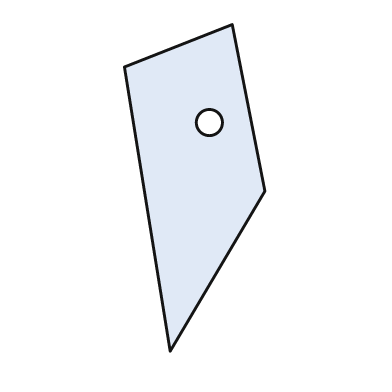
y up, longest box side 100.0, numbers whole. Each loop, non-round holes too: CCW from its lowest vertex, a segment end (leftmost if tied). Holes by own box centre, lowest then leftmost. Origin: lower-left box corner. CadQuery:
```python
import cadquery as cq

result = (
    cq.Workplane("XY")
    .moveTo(14.0, 0.0)
    .lineTo(43.0, 49.0)
    .lineTo(33.0, 100.0)
    .lineTo(0.0, 87.0)
    .close()
    .moveTo(26.0, 70.0)
    .circle(4.0)
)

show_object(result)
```